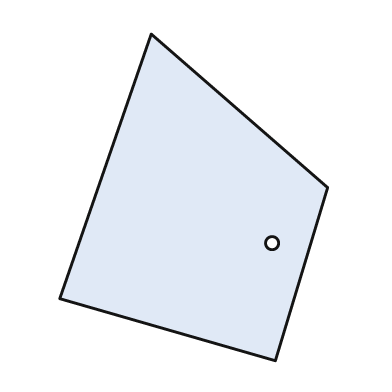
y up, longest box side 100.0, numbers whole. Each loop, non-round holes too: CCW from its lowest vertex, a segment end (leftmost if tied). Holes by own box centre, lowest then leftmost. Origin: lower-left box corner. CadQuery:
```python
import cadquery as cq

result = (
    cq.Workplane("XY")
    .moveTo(66.0, 0.0)
    .lineTo(82.0, 53.0)
    .lineTo(28.0, 100.0)
    .lineTo(0.0, 19.0)
    .close()
    .moveTo(65.0, 36.0)
    .circle(2.0)
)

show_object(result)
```